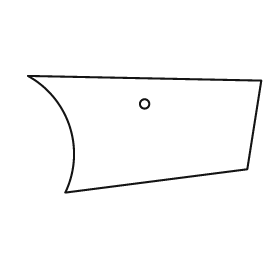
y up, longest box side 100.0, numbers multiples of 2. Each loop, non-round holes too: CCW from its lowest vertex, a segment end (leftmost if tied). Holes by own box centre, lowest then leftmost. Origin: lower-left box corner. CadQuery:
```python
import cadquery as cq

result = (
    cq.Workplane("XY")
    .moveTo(16.0, 0.0)
    .lineTo(94.0, 10.0)
    .lineTo(100.0, 48.0)
    .lineTo(0.0, 50.0)
    .threePointArc((18.0, 28.0), (16.0, 0.0))
    .close()
    .moveTo(50.0, 38.0)
    .circle(2.0)
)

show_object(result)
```